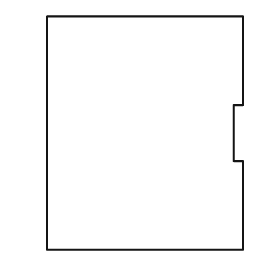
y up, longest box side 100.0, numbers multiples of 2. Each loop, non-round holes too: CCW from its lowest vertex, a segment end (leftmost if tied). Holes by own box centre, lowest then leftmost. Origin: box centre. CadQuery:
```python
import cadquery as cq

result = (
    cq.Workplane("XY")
    .moveTo(-42.0, -50.0)
    .lineTo(42.0, -50.0)
    .lineTo(42.0, -12.0)
    .lineTo(38.0, -12.0)
    .lineTo(38.0, 12.0)
    .lineTo(42.0, 12.0)
    .lineTo(42.0, 50.0)
    .lineTo(-42.0, 50.0)
    .close()
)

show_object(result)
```